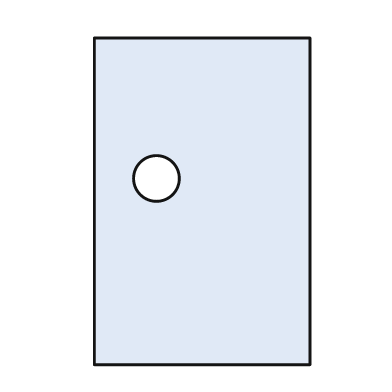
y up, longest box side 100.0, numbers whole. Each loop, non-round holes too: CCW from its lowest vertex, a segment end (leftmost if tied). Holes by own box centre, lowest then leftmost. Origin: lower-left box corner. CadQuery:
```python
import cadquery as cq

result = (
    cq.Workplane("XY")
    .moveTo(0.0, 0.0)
    .lineTo(66.0, 0.0)
    .lineTo(66.0, 100.0)
    .lineTo(0.0, 100.0)
    .close()
    .moveTo(19.0, 57.0)
    .circle(7.0)
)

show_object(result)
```